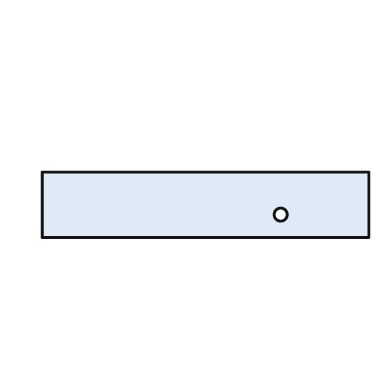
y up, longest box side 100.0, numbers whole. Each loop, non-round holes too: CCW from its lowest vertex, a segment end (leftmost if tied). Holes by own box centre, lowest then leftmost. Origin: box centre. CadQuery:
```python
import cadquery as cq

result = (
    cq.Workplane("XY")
    .moveTo(-50.0, -10.0)
    .lineTo(50.0, -10.0)
    .lineTo(50.0, 10.0)
    .lineTo(-50.0, 10.0)
    .close()
    .moveTo(23.0, -3.0)
    .circle(2.0)
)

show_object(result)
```